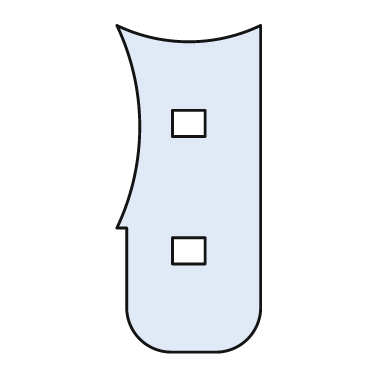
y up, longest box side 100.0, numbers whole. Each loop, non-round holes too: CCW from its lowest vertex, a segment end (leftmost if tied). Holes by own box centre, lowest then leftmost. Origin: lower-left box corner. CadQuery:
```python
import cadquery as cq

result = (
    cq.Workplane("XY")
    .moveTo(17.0, 0.0)
    .lineTo(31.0, 0.0)
    .threePointArc((40.0, 4.0), (44.0, 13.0))
    .lineTo(44.0, 100.0)
    .threePointArc((22.0, 95.0), (0.0, 100.0))
    .threePointArc((7.0, 69.0), (0.0, 38.0))
    .lineTo(3.0, 38.0)
    .lineTo(3.0, 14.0)
    .threePointArc((7.0, 4.0), (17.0, 0.0))
    .close()
    .moveTo(17.0, 27.0)
    .lineTo(27.0, 27.0)
    .lineTo(27.0, 35.0)
    .lineTo(17.0, 35.0)
    .close()
    .moveTo(17.0, 66.0)
    .lineTo(27.0, 66.0)
    .lineTo(27.0, 74.0)
    .lineTo(17.0, 74.0)
    .close()
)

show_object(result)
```